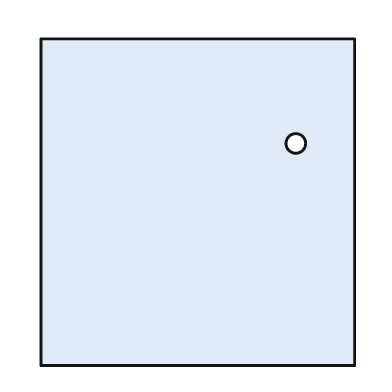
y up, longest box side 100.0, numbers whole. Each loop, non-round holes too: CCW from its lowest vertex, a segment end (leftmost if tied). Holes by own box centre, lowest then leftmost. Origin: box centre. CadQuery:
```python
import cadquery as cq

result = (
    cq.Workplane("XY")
    .moveTo(-48.0, -50.0)
    .lineTo(48.0, -50.0)
    .lineTo(48.0, 50.0)
    .lineTo(-48.0, 50.0)
    .close()
    .moveTo(30.0, 18.0)
    .circle(3.0)
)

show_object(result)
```